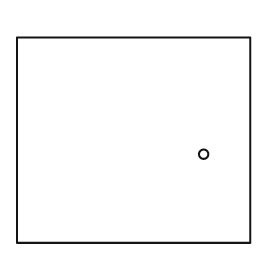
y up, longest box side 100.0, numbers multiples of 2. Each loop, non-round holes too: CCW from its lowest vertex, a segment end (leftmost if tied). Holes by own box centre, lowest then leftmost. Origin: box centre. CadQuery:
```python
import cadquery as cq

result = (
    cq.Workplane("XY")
    .moveTo(-50.0, -44.0)
    .lineTo(50.0, -44.0)
    .lineTo(50.0, 44.0)
    .lineTo(-50.0, 44.0)
    .close()
    .moveTo(30.0, -6.0)
    .circle(2.0)
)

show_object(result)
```